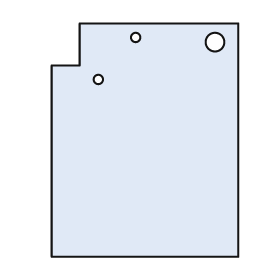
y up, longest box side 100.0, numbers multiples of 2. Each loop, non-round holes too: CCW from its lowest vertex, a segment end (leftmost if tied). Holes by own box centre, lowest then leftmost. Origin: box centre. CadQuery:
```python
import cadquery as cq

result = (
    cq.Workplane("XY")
    .moveTo(-40.0, -50.0)
    .lineTo(40.0, -50.0)
    .lineTo(40.0, 50.0)
    .lineTo(-28.0, 50.0)
    .lineTo(-28.0, 32.0)
    .lineTo(-40.0, 32.0)
    .close()
    .moveTo(-20.0, 26.0)
    .circle(2.0)
    .moveTo(30.0, 42.0)
    .circle(4.0)
    .moveTo(-4.0, 44.0)
    .circle(2.0)
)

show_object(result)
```